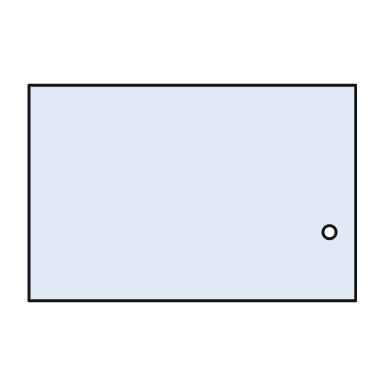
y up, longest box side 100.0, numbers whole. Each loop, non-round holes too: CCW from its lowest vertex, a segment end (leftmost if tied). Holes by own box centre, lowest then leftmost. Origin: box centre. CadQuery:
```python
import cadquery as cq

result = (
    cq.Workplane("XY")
    .moveTo(-50.0, -33.0)
    .lineTo(50.0, -33.0)
    .lineTo(50.0, 33.0)
    .lineTo(-50.0, 33.0)
    .close()
    .moveTo(42.0, -12.0)
    .circle(2.0)
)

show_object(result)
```